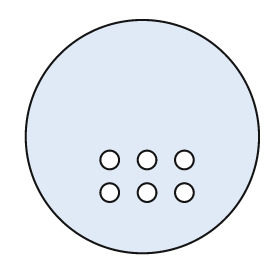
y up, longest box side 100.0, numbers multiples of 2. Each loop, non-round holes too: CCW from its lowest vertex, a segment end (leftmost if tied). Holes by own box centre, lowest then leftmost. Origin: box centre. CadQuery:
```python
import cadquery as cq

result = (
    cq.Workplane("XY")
    .moveTo(0.0, 0.0)
    .circle(50.0)
    .moveTo(-14.0, -24.0)
    .circle(4.0)
    .moveTo(2.0, -24.0)
    .circle(4.0)
    .moveTo(18.0, -24.0)
    .circle(4.0)
    .moveTo(-14.0, -10.0)
    .circle(4.0)
    .moveTo(2.0, -10.0)
    .circle(4.0)
    .moveTo(18.0, -10.0)
    .circle(4.0)
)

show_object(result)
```